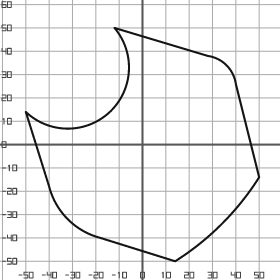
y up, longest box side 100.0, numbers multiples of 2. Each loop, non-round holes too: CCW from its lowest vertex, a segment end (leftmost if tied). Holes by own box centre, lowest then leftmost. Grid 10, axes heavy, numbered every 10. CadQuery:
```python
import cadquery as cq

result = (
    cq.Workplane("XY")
    .moveTo(14.0, -50.0)
    .threePointArc((34.0, -34.0), (50.0, -14.0))
    .lineTo(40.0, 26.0)
    .threePointArc((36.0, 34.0), (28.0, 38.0))
    .lineTo(-12.0, 50.0)
    .threePointArc((-14.0, 14.0), (-50.0, 14.0))
    .lineTo(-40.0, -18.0)
    .threePointArc((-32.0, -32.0), (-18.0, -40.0))
    .close()
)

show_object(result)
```